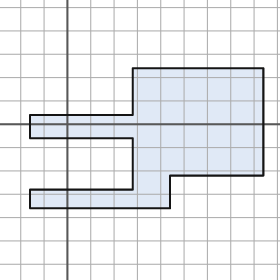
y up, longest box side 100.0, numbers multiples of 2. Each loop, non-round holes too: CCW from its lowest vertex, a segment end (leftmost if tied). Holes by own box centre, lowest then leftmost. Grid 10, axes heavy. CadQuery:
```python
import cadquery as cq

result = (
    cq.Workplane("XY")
    .moveTo(-16.0, -36.0)
    .lineTo(44.0, -36.0)
    .lineTo(44.0, -22.0)
    .lineTo(84.0, -22.0)
    .lineTo(84.0, 24.0)
    .lineTo(28.0, 24.0)
    .lineTo(28.0, 4.0)
    .lineTo(-16.0, 4.0)
    .lineTo(-16.0, -6.0)
    .lineTo(28.0, -6.0)
    .lineTo(28.0, -28.0)
    .lineTo(-16.0, -28.0)
    .close()
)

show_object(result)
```